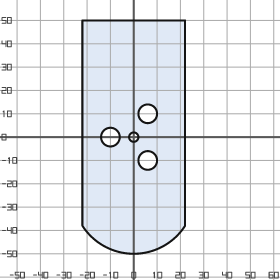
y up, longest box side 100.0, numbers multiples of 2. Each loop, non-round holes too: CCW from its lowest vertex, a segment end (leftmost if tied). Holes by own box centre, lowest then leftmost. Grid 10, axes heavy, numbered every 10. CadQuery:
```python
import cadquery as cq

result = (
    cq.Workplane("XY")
    .moveTo(-22.0, -38.0)
    .threePointArc((0.0, -50.0), (22.0, -38.0))
    .lineTo(22.0, 50.0)
    .lineTo(-22.0, 50.0)
    .close()
    .moveTo(6.0, -10.0)
    .circle(4.0)
    .moveTo(-10.0, 0.0)
    .circle(4.0)
    .moveTo(0.0, 0.0)
    .circle(2.0)
    .moveTo(6.0, 10.0)
    .circle(4.0)
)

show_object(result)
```